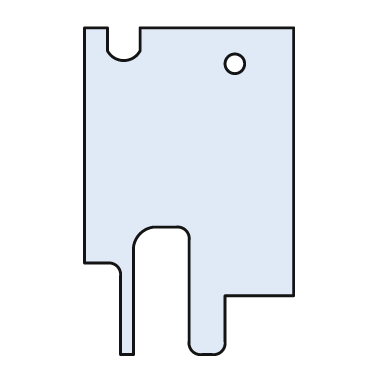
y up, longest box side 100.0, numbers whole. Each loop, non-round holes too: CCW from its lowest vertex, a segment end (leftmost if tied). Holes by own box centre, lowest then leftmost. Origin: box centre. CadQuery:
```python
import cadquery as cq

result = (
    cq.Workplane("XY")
    .moveTo(-21.0, -50.0)
    .lineTo(-17.0, -50.0)
    .lineTo(-17.0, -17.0)
    .threePointArc((-15.0, -13.0), (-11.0, -11.0))
    .lineTo(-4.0, -11.0)
    .threePointArc((-1.0, -12.0), (0.0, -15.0))
    .lineTo(0.0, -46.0)
    .threePointArc((1.0, -49.0), (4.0, -50.0))
    .lineTo(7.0, -50.0)
    .threePointArc((10.0, -49.0), (11.0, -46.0))
    .lineTo(11.0, -32.0)
    .lineTo(32.0, -32.0)
    .lineTo(32.0, 50.0)
    .lineTo(-15.0, 50.0)
    .lineTo(-15.0, 43.0)
    .threePointArc((-20.0, 40.0), (-25.0, 43.0))
    .lineTo(-25.0, 50.0)
    .lineTo(-32.0, 50.0)
    .lineTo(-32.0, -22.0)
    .lineTo(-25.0, -22.0)
    .threePointArc((-22.0, -23.0), (-21.0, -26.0))
    .close()
    .moveTo(14.0, 39.0)
    .circle(3.0)
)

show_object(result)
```